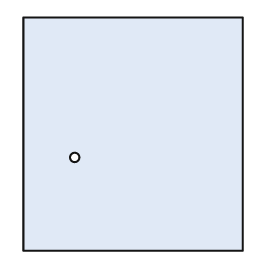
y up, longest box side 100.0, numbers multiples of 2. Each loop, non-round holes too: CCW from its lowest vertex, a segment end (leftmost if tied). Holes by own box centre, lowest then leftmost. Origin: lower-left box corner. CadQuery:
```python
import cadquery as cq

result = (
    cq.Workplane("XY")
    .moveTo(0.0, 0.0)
    .lineTo(94.0, 0.0)
    .lineTo(94.0, 100.0)
    .lineTo(0.0, 100.0)
    .close()
    .moveTo(22.0, 40.0)
    .circle(2.0)
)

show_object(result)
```